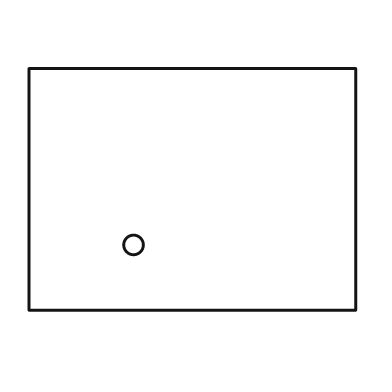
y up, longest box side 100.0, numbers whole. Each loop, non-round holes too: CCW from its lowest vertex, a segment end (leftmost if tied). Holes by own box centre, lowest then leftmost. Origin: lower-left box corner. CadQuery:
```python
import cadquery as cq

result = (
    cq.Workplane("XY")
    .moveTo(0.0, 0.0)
    .lineTo(100.0, 0.0)
    .lineTo(100.0, 74.0)
    .lineTo(0.0, 74.0)
    .close()
    .moveTo(32.0, 20.0)
    .circle(3.0)
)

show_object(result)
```